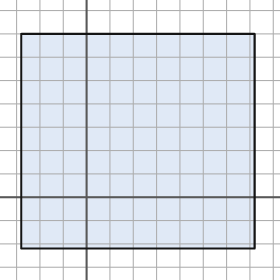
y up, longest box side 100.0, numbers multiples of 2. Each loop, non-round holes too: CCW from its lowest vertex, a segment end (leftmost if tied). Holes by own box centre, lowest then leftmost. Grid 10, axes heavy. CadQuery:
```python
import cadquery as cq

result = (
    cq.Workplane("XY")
    .moveTo(-28.0, -22.0)
    .lineTo(72.0, -22.0)
    .lineTo(72.0, 70.0)
    .lineTo(-28.0, 70.0)
    .close()
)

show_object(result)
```